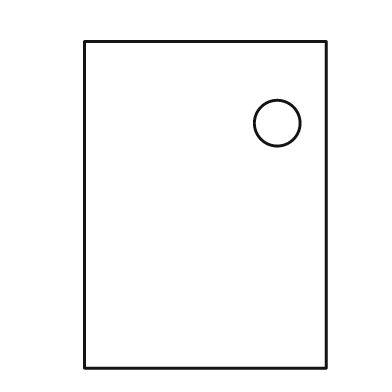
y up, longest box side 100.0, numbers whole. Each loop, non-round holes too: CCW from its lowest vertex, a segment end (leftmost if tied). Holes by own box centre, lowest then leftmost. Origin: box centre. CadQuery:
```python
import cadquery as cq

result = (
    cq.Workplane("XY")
    .moveTo(-37.0, -50.0)
    .lineTo(37.0, -50.0)
    .lineTo(37.0, 50.0)
    .lineTo(-37.0, 50.0)
    .close()
    .moveTo(22.0, 25.0)
    .circle(7.0)
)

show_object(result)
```